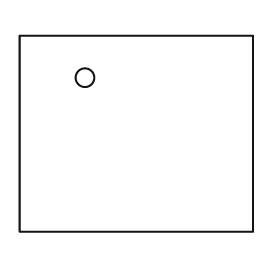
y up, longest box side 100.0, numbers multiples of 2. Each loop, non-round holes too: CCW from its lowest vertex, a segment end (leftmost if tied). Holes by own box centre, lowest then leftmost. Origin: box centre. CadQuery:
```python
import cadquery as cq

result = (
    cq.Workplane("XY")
    .moveTo(-50.0, -42.0)
    .lineTo(50.0, -42.0)
    .lineTo(50.0, 42.0)
    .lineTo(-50.0, 42.0)
    .close()
    .moveTo(-22.0, 24.0)
    .circle(4.0)
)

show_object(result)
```